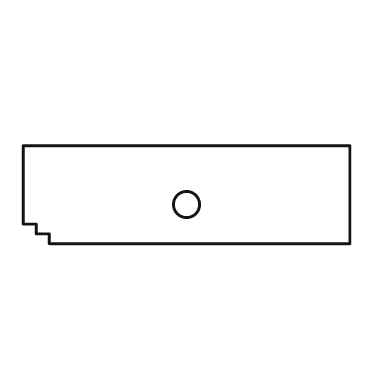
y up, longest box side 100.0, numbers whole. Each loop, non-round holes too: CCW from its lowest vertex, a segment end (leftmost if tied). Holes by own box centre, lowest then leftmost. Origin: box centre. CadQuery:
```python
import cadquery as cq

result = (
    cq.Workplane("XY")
    .moveTo(-42.0, -15.0)
    .lineTo(50.0, -15.0)
    .lineTo(50.0, 15.0)
    .lineTo(-50.0, 15.0)
    .lineTo(-50.0, -9.0)
    .lineTo(-46.0, -9.0)
    .lineTo(-46.0, -12.0)
    .lineTo(-42.0, -12.0)
    .close()
    .moveTo(0.0, -3.0)
    .circle(4.0)
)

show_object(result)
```